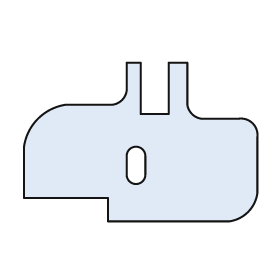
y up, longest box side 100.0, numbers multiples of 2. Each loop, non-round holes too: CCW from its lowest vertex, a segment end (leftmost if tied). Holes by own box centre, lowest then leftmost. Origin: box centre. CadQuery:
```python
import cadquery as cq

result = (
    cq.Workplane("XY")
    .moveTo(-14.0, -34.0)
    .lineTo(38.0, -34.0)
    .threePointArc((46.0, -30.0), (50.0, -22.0))
    .lineTo(50.0, 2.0)
    .threePointArc((48.0, 8.0), (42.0, 10.0))
    .lineTo(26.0, 10.0)
    .threePointArc((22.0, 12.0), (20.0, 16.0))
    .lineTo(20.0, 34.0)
    .lineTo(12.0, 34.0)
    .lineTo(12.0, 12.0)
    .lineTo(0.0, 12.0)
    .lineTo(0.0, 34.0)
    .lineTo(-6.0, 34.0)
    .lineTo(-6.0, 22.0)
    .threePointArc((-8.0, 18.0), (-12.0, 16.0))
    .lineTo(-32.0, 16.0)
    .threePointArc((-44.0, 10.0), (-50.0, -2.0))
    .lineTo(-50.0, -24.0)
    .lineTo(-14.0, -24.0)
    .close()
    .moveTo(-6.0, -14.0)
    .threePointArc((-2.0, -18.0), (2.0, -14.0))
    .lineTo(2.0, -6.0)
    .threePointArc((-2.0, -2.0), (-6.0, -6.0))
    .close()
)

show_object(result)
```